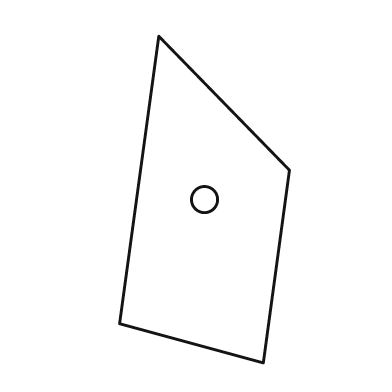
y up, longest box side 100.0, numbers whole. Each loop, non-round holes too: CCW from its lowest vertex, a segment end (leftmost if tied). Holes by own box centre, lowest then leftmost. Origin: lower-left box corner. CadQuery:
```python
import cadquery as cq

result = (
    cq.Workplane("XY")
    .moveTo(44.0, 0.0)
    .lineTo(52.0, 59.0)
    .lineTo(12.0, 100.0)
    .lineTo(0.0, 12.0)
    .close()
    .moveTo(26.0, 50.0)
    .circle(4.0)
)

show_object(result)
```